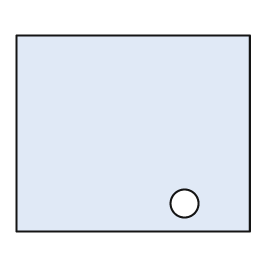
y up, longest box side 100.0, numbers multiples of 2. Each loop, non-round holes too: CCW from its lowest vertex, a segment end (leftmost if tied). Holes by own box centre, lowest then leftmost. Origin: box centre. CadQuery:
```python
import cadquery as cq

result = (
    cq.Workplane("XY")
    .moveTo(-50.0, -42.0)
    .lineTo(50.0, -42.0)
    .lineTo(50.0, 42.0)
    .lineTo(-50.0, 42.0)
    .close()
    .moveTo(22.0, -30.0)
    .circle(6.0)
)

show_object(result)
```